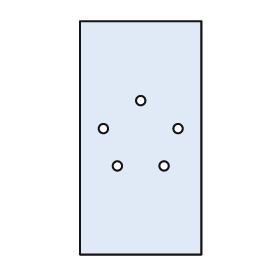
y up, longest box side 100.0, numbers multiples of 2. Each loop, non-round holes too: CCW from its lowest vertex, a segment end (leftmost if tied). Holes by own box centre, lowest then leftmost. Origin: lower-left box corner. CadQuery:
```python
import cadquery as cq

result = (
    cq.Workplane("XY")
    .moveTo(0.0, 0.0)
    .lineTo(52.0, 0.0)
    .lineTo(52.0, 100.0)
    .lineTo(0.0, 100.0)
    .close()
    .moveTo(16.0, 38.0)
    .circle(2.0)
    .moveTo(36.0, 38.0)
    .circle(2.0)
    .moveTo(10.0, 54.0)
    .circle(2.0)
    .moveTo(42.0, 54.0)
    .circle(2.0)
    .moveTo(26.0, 66.0)
    .circle(2.0)
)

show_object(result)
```